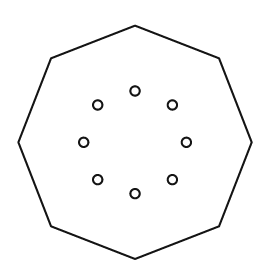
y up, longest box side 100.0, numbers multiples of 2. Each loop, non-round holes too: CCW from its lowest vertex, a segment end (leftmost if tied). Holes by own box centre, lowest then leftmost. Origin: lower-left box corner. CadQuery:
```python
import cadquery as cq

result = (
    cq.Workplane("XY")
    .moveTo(50.0, 0.0)
    .lineTo(86.0, 14.0)
    .lineTo(100.0, 50.0)
    .lineTo(86.0, 86.0)
    .lineTo(50.0, 100.0)
    .lineTo(14.0, 86.0)
    .lineTo(0.0, 50.0)
    .lineTo(14.0, 14.0)
    .close()
    .moveTo(50.0, 28.0)
    .circle(2.0)
    .moveTo(34.0, 34.0)
    .circle(2.0)
    .moveTo(66.0, 34.0)
    .circle(2.0)
    .moveTo(28.0, 50.0)
    .circle(2.0)
    .moveTo(72.0, 50.0)
    .circle(2.0)
    .moveTo(34.0, 66.0)
    .circle(2.0)
    .moveTo(66.0, 66.0)
    .circle(2.0)
    .moveTo(50.0, 72.0)
    .circle(2.0)
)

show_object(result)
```